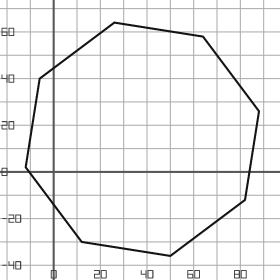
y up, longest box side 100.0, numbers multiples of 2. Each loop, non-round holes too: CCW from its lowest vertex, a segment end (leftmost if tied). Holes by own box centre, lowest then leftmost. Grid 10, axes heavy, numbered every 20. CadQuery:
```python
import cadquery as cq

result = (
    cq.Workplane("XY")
    .moveTo(50.0, -36.0)
    .lineTo(82.0, -12.0)
    .lineTo(88.0, 26.0)
    .lineTo(64.0, 58.0)
    .lineTo(26.0, 64.0)
    .lineTo(-6.0, 40.0)
    .lineTo(-12.0, 2.0)
    .lineTo(12.0, -30.0)
    .close()
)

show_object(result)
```